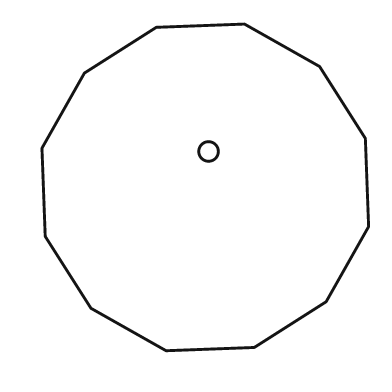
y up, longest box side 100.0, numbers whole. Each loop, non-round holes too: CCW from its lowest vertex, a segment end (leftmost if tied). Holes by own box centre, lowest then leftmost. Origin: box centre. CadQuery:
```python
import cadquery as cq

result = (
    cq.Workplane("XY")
    .moveTo(-12.0, -50.0)
    .lineTo(15.0, -49.0)
    .lineTo(37.0, -35.0)
    .lineTo(50.0, -12.0)
    .lineTo(49.0, 15.0)
    .lineTo(35.0, 37.0)
    .lineTo(12.0, 50.0)
    .lineTo(-15.0, 49.0)
    .lineTo(-37.0, 35.0)
    .lineTo(-50.0, 12.0)
    .lineTo(-49.0, -15.0)
    .lineTo(-35.0, -37.0)
    .close()
    .moveTo(1.0, 11.0)
    .circle(3.0)
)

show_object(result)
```